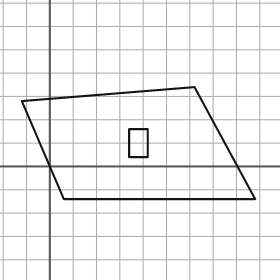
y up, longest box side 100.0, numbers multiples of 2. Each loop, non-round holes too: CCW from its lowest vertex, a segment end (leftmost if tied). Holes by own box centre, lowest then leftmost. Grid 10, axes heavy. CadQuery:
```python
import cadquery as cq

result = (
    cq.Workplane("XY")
    .moveTo(6.0, -14.0)
    .lineTo(88.0, -14.0)
    .lineTo(62.0, 34.0)
    .lineTo(-12.0, 28.0)
    .close()
    .moveTo(34.0, 4.0)
    .lineTo(42.0, 4.0)
    .lineTo(42.0, 16.0)
    .lineTo(34.0, 16.0)
    .close()
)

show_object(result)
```